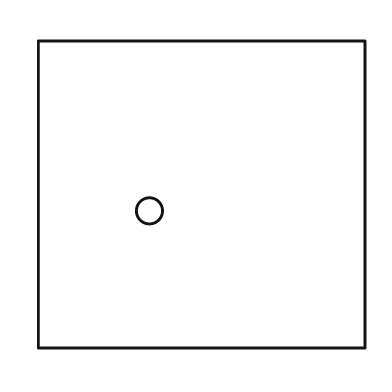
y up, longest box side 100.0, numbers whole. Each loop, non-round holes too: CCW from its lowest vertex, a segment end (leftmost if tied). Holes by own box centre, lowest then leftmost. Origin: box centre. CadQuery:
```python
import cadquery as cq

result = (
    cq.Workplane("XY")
    .moveTo(-50.0, -47.0)
    .lineTo(50.0, -47.0)
    .lineTo(50.0, 47.0)
    .lineTo(-50.0, 47.0)
    .close()
    .moveTo(-16.0, -5.0)
    .circle(4.0)
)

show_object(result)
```